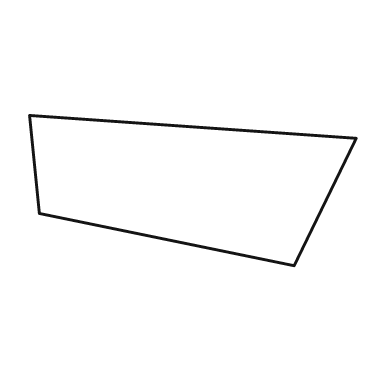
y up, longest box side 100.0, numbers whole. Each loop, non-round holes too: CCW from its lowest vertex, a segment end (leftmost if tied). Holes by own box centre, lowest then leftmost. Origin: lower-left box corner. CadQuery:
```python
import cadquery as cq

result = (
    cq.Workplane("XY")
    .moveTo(81.0, 0.0)
    .lineTo(100.0, 39.0)
    .lineTo(0.0, 46.0)
    .lineTo(3.0, 16.0)
    .close()
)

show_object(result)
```